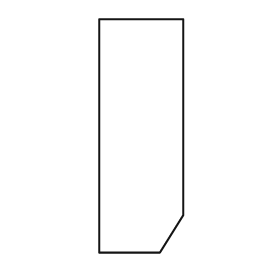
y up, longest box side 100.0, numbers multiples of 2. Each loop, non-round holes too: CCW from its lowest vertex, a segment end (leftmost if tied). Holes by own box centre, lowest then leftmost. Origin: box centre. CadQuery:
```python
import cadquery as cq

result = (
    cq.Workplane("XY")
    .moveTo(-18.0, -50.0)
    .lineTo(8.0, -50.0)
    .lineTo(18.0, -34.0)
    .lineTo(18.0, 50.0)
    .lineTo(-18.0, 50.0)
    .close()
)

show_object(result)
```